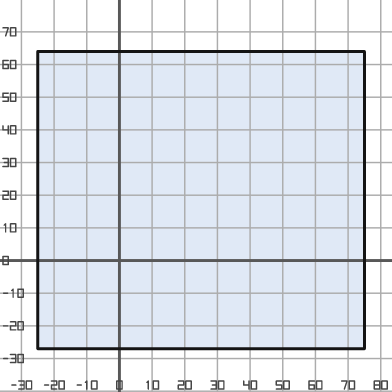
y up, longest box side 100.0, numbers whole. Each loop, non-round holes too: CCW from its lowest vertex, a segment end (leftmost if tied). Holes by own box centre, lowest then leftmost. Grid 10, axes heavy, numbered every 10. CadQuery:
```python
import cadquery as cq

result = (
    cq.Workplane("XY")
    .moveTo(-25.0, -27.0)
    .lineTo(75.0, -27.0)
    .lineTo(75.0, 64.0)
    .lineTo(-25.0, 64.0)
    .close()
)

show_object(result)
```